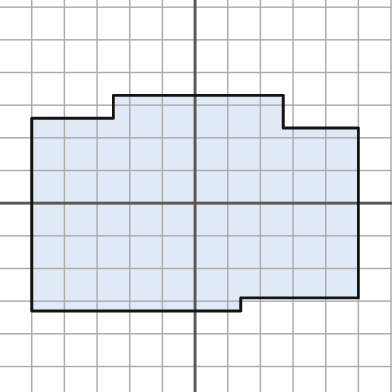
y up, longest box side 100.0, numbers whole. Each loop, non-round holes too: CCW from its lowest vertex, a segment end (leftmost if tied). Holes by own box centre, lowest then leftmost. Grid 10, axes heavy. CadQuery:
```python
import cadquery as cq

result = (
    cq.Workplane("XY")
    .moveTo(-50.0, -33.0)
    .lineTo(14.0, -33.0)
    .lineTo(14.0, -29.0)
    .lineTo(50.0, -29.0)
    .lineTo(50.0, 23.0)
    .lineTo(27.0, 23.0)
    .lineTo(27.0, 33.0)
    .lineTo(-25.0, 33.0)
    .lineTo(-25.0, 26.0)
    .lineTo(-50.0, 26.0)
    .close()
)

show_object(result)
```